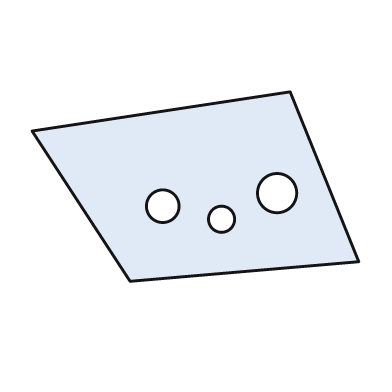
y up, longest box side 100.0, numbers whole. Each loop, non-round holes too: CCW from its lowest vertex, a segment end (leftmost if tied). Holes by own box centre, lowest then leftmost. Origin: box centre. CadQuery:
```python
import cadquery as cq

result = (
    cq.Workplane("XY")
    .moveTo(-20.0, -29.0)
    .lineTo(50.0, -23.0)
    .lineTo(29.0, 29.0)
    .lineTo(-50.0, 17.0)
    .close()
    .moveTo(8.0, -10.0)
    .circle(4.0)
    .moveTo(-10.0, -6.0)
    .circle(5.0)
    .moveTo(25.0, -2.0)
    .circle(6.0)
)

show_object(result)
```